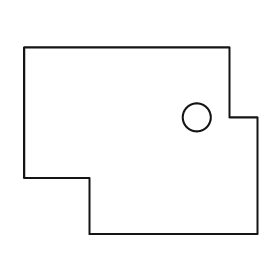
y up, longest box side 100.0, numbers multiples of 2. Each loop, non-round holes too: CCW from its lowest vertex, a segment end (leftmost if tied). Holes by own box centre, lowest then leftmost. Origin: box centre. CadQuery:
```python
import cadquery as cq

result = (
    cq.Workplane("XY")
    .moveTo(-22.0, -40.0)
    .lineTo(50.0, -40.0)
    .lineTo(50.0, 10.0)
    .lineTo(38.0, 10.0)
    .lineTo(38.0, 40.0)
    .lineTo(-50.0, 40.0)
    .lineTo(-50.0, -16.0)
    .lineTo(-22.0, -16.0)
    .close()
    .moveTo(24.0, 10.0)
    .circle(6.0)
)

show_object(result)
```